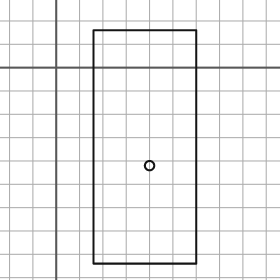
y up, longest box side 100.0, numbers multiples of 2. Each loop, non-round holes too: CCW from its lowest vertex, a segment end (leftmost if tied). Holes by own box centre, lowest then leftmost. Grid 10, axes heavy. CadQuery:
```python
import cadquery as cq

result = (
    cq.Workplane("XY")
    .moveTo(16.0, -84.0)
    .lineTo(60.0, -84.0)
    .lineTo(60.0, 16.0)
    .lineTo(16.0, 16.0)
    .close()
    .moveTo(40.0, -42.0)
    .circle(2.0)
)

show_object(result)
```